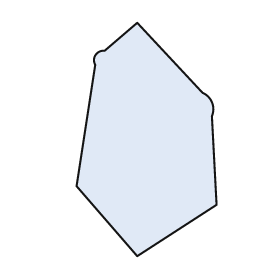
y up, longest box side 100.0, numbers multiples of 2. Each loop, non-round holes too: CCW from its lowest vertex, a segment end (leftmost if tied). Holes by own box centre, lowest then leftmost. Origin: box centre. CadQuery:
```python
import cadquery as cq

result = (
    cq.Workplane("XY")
    .moveTo(-4.0, -50.0)
    .lineTo(30.0, -28.0)
    .lineTo(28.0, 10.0)
    .threePointArc((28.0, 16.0), (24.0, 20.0))
    .lineTo(-4.0, 50.0)
    .lineTo(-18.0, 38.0)
    .threePointArc((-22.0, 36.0), (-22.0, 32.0))
    .lineTo(-30.0, -20.0)
    .close()
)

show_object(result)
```